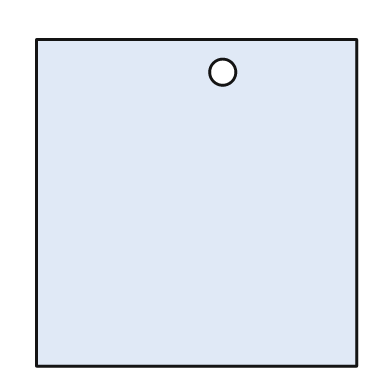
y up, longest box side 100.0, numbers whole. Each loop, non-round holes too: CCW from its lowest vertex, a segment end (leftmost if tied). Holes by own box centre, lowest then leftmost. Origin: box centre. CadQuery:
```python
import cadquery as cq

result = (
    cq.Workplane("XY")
    .moveTo(-49.0, -50.0)
    .lineTo(49.0, -50.0)
    .lineTo(49.0, 50.0)
    .lineTo(-49.0, 50.0)
    .close()
    .moveTo(8.0, 40.0)
    .circle(4.0)
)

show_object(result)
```